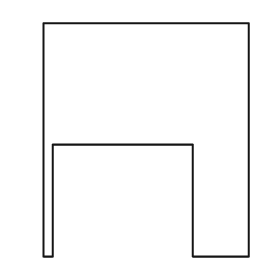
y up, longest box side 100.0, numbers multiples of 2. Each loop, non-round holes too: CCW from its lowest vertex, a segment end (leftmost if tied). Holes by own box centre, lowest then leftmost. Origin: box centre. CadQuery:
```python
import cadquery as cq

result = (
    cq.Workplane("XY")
    .moveTo(-44.0, -50.0)
    .lineTo(-40.0, -50.0)
    .lineTo(-40.0, -2.0)
    .lineTo(20.0, -2.0)
    .lineTo(20.0, -50.0)
    .lineTo(44.0, -50.0)
    .lineTo(44.0, 50.0)
    .lineTo(-44.0, 50.0)
    .close()
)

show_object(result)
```